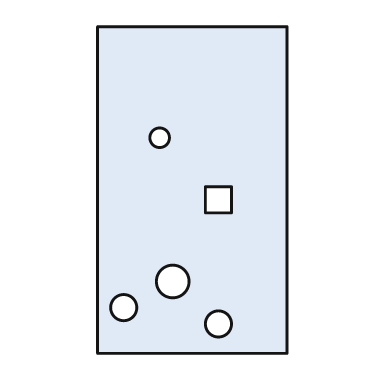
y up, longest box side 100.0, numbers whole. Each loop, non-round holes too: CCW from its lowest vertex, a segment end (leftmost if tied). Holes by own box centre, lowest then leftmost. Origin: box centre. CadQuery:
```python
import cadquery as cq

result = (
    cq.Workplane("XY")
    .moveTo(-29.0, -50.0)
    .lineTo(29.0, -50.0)
    .lineTo(29.0, 50.0)
    .lineTo(-29.0, 50.0)
    .close()
    .moveTo(8.0, -41.0)
    .circle(4.0)
    .moveTo(-21.0, -36.0)
    .circle(4.0)
    .moveTo(-6.0, -28.0)
    .circle(5.0)
    .moveTo(4.0, -7.0)
    .lineTo(12.0, -7.0)
    .lineTo(12.0, 1.0)
    .lineTo(4.0, 1.0)
    .close()
    .moveTo(-10.0, 16.0)
    .circle(3.0)
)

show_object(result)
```